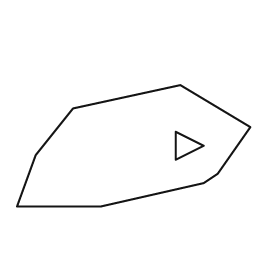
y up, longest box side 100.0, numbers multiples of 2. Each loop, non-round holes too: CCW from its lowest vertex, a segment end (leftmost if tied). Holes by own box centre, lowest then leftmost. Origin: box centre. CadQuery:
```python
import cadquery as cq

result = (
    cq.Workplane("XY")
    .moveTo(-50.0, -26.0)
    .lineTo(-14.0, -26.0)
    .lineTo(30.0, -16.0)
    .lineTo(36.0, -12.0)
    .lineTo(50.0, 8.0)
    .lineTo(20.0, 26.0)
    .lineTo(-26.0, 16.0)
    .lineTo(-42.0, -4.0)
    .close()
    .moveTo(18.0, -6.0)
    .lineTo(30.0, 0.0)
    .lineTo(18.0, 6.0)
    .close()
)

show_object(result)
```